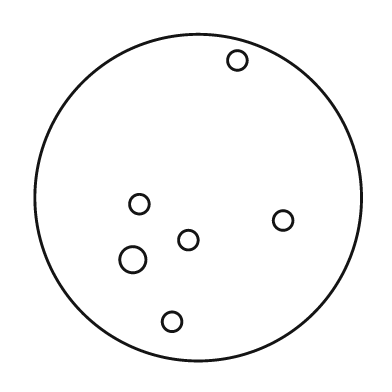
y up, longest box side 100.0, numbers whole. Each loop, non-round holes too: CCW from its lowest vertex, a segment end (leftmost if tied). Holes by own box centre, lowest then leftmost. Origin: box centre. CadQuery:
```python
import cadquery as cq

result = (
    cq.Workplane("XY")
    .moveTo(0.0, 0.0)
    .circle(50.0)
    .moveTo(-8.0, -38.0)
    .circle(3.0)
    .moveTo(-20.0, -19.0)
    .circle(4.0)
    .moveTo(-3.0, -13.0)
    .circle(3.0)
    .moveTo(26.0, -7.0)
    .circle(3.0)
    .moveTo(-18.0, -2.0)
    .circle(3.0)
    .moveTo(12.0, 42.0)
    .circle(3.0)
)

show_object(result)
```